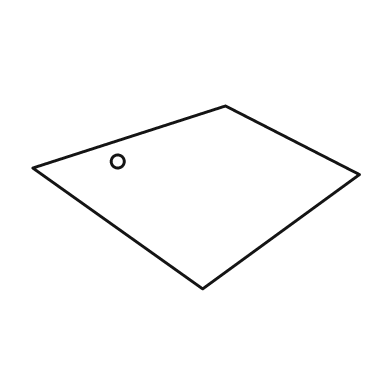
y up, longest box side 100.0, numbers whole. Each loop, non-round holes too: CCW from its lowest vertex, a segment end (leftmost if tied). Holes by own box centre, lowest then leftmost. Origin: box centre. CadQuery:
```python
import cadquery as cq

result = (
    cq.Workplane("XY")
    .moveTo(2.0, -28.0)
    .lineTo(50.0, 7.0)
    .lineTo(9.0, 28.0)
    .lineTo(-50.0, 9.0)
    .close()
    .moveTo(-24.0, 11.0)
    .circle(2.0)
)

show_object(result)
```